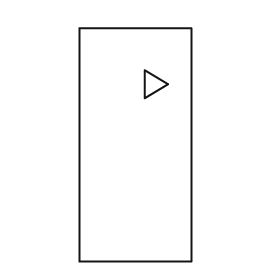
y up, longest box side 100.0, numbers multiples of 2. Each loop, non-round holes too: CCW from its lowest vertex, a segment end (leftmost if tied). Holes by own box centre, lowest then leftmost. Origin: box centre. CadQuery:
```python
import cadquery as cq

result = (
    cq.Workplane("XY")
    .moveTo(-24.0, -50.0)
    .lineTo(24.0, -50.0)
    .lineTo(24.0, 50.0)
    .lineTo(-24.0, 50.0)
    .close()
    .moveTo(4.0, 20.0)
    .lineTo(14.0, 26.0)
    .lineTo(4.0, 32.0)
    .close()
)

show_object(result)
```